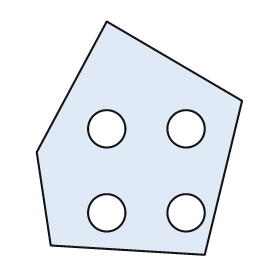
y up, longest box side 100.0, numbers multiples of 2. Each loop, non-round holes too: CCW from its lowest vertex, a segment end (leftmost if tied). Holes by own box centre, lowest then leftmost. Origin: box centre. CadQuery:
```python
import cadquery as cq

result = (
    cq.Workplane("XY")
    .moveTo(28.0, -50.0)
    .lineTo(44.0, 16.0)
    .lineTo(-14.0, 50.0)
    .lineTo(-44.0, -6.0)
    .lineTo(-38.0, -46.0)
    .close()
    .moveTo(-14.0, -32.0)
    .circle(8.0)
    .moveTo(20.0, -32.0)
    .circle(8.0)
    .moveTo(-14.0, 4.0)
    .circle(8.0)
    .moveTo(20.0, 4.0)
    .circle(8.0)
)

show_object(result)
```